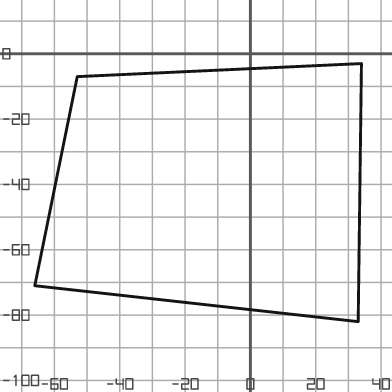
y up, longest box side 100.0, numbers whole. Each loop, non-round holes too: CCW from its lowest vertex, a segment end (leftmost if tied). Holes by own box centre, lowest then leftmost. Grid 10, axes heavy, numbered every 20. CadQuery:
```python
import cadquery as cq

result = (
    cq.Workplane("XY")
    .moveTo(33.0, -82.0)
    .lineTo(34.0, -3.0)
    .lineTo(-53.0, -7.0)
    .lineTo(-66.0, -71.0)
    .close()
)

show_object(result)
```